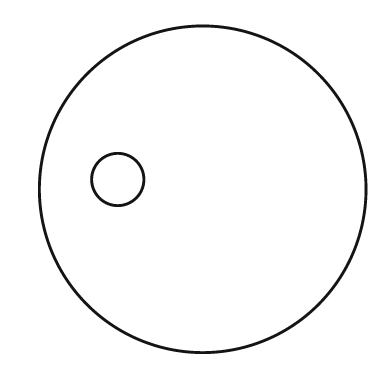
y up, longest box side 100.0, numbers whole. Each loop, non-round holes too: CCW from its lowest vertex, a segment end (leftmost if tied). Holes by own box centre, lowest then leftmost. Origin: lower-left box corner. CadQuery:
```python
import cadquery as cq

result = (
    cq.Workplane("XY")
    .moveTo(50.0, 50.0)
    .circle(50.0)
    .moveTo(24.0, 53.0)
    .circle(8.0)
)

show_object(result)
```